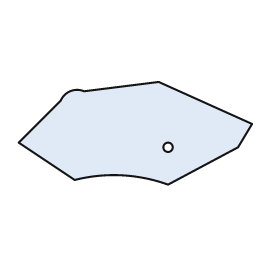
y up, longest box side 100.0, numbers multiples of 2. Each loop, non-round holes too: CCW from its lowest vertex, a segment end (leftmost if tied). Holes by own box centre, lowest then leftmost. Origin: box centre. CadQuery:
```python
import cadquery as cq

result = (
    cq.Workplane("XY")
    .moveTo(14.0, -22.0)
    .lineTo(44.0, -6.0)
    .lineTo(50.0, 4.0)
    .lineTo(10.0, 22.0)
    .lineTo(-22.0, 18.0)
    .threePointArc((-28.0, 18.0), (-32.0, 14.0))
    .lineTo(-50.0, -4.0)
    .lineTo(-26.0, -20.0)
    .threePointArc((-6.0, -18.0), (14.0, -22.0))
    .close()
    .moveTo(14.0, -6.0)
    .circle(2.0)
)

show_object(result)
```